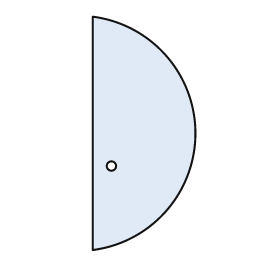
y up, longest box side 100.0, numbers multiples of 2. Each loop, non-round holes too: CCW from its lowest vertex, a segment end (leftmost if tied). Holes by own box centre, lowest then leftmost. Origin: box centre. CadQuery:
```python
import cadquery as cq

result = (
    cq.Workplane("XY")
    .moveTo(-22.0, -50.0)
    .threePointArc((22.0, 0.0), (-22.0, 50.0))
    .close()
    .moveTo(-14.0, -14.0)
    .circle(2.0)
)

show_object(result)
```